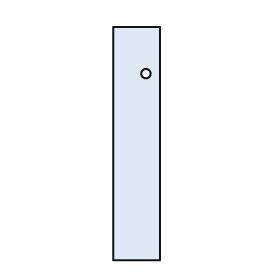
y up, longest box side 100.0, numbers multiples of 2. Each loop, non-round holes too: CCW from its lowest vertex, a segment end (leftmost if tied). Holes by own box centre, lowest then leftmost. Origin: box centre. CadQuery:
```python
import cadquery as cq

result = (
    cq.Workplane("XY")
    .moveTo(-10.0, -50.0)
    .lineTo(10.0, -50.0)
    .lineTo(10.0, 50.0)
    .lineTo(-10.0, 50.0)
    .close()
    .moveTo(4.0, 30.0)
    .circle(2.0)
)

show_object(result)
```